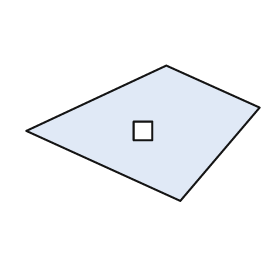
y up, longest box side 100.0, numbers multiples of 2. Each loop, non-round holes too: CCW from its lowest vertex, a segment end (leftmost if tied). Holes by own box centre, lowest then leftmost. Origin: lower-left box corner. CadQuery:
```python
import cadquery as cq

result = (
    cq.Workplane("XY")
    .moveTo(66.0, 0.0)
    .lineTo(100.0, 40.0)
    .lineTo(60.0, 58.0)
    .lineTo(0.0, 30.0)
    .close()
    .moveTo(46.0, 26.0)
    .lineTo(54.0, 26.0)
    .lineTo(54.0, 34.0)
    .lineTo(46.0, 34.0)
    .close()
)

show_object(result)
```